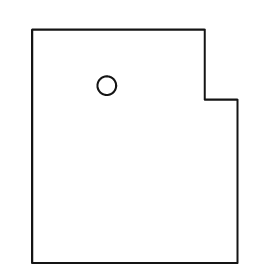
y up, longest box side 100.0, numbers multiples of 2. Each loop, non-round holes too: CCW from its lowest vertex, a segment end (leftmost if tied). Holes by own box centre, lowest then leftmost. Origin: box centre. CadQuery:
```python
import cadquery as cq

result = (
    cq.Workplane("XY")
    .moveTo(-44.0, -50.0)
    .lineTo(44.0, -50.0)
    .lineTo(44.0, 20.0)
    .lineTo(30.0, 20.0)
    .lineTo(30.0, 50.0)
    .lineTo(-44.0, 50.0)
    .close()
    .moveTo(-12.0, 26.0)
    .circle(4.0)
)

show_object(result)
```